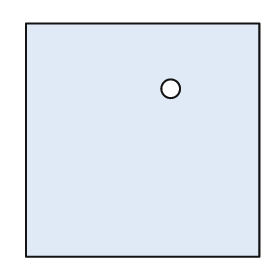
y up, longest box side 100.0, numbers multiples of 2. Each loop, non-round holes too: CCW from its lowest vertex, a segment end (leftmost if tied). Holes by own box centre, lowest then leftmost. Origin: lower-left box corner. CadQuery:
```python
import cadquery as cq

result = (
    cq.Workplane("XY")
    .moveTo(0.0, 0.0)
    .lineTo(100.0, 0.0)
    .lineTo(100.0, 100.0)
    .lineTo(0.0, 100.0)
    .close()
    .moveTo(62.0, 72.0)
    .circle(4.0)
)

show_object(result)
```